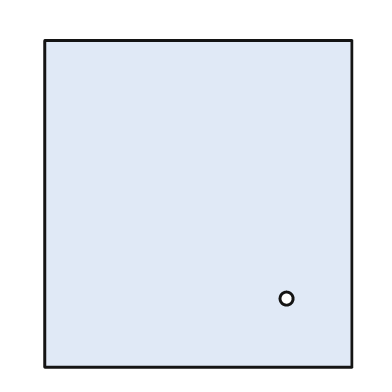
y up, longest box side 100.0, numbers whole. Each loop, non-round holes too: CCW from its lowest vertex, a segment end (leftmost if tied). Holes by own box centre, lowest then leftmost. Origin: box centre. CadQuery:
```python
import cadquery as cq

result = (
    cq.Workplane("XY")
    .moveTo(-47.0, -50.0)
    .lineTo(47.0, -50.0)
    .lineTo(47.0, 50.0)
    .lineTo(-47.0, 50.0)
    .close()
    .moveTo(27.0, -29.0)
    .circle(2.0)
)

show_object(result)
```